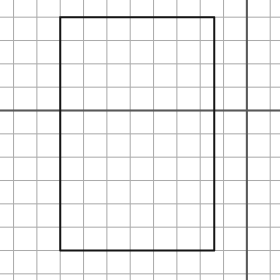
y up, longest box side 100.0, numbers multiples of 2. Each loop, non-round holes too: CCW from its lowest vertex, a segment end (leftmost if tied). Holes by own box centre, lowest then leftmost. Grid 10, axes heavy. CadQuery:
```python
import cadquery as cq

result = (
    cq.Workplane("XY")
    .moveTo(-80.0, -60.0)
    .lineTo(-14.0, -60.0)
    .lineTo(-14.0, 40.0)
    .lineTo(-80.0, 40.0)
    .close()
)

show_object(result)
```